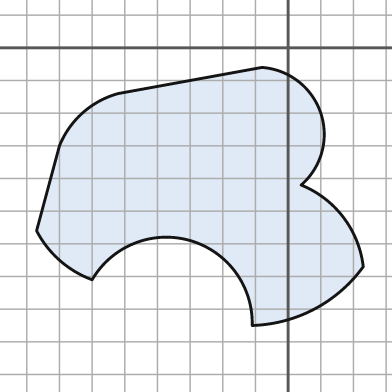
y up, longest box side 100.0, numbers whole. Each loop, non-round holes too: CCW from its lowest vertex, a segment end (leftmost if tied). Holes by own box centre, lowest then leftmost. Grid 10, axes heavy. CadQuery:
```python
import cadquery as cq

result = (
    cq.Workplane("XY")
    .moveTo(-11.0, -85.0)
    .threePointArc((8.0, -80.0), (23.0, -67.0))
    .threePointArc((17.0, -52.0), (4.0, -42.0))
    .threePointArc((10.0, -20.0), (-8.0, -6.0))
    .lineTo(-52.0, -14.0)
    .threePointArc((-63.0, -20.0), (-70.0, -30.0))
    .lineTo(-77.0, -56.0)
    .threePointArc((-70.0, -65.0), (-60.0, -71.0))
    .threePointArc((-30.0, -59.0), (-11.0, -85.0))
    .close()
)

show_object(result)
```